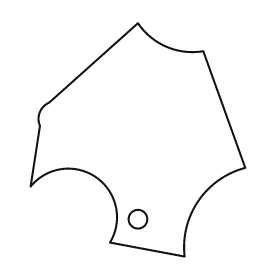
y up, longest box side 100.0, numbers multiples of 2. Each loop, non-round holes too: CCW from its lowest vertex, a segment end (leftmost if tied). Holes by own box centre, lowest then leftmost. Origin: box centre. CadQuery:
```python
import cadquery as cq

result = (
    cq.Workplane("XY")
    .moveTo(20.0, -50.0)
    .threePointArc((26.0, -26.0), (46.0, -12.0))
    .lineTo(28.0, 38.0)
    .threePointArc((12.0, 40.0), (0.0, 50.0))
    .lineTo(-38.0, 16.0)
    .threePointArc((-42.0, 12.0), (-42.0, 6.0))
    .lineTo(-46.0, -20.0)
    .threePointArc((-18.0, -16.0), (-12.0, -44.0))
    .close()
    .moveTo(0.0, -34.0)
    .circle(4.0)
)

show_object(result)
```